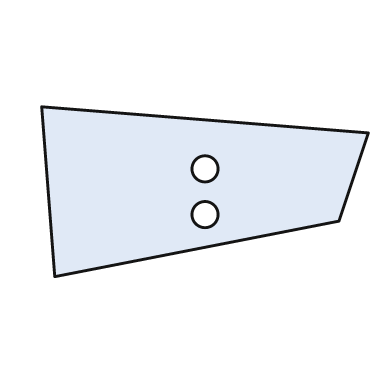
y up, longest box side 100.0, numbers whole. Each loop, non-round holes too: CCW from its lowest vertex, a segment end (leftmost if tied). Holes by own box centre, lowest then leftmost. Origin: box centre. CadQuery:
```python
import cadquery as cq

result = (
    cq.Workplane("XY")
    .moveTo(-46.0, -26.0)
    .lineTo(41.0, -9.0)
    .lineTo(50.0, 18.0)
    .lineTo(-50.0, 26.0)
    .close()
    .moveTo(0.0, -7.0)
    .circle(4.0)
    .moveTo(0.0, 7.0)
    .circle(4.0)
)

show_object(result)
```